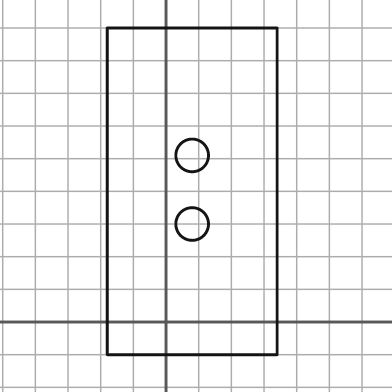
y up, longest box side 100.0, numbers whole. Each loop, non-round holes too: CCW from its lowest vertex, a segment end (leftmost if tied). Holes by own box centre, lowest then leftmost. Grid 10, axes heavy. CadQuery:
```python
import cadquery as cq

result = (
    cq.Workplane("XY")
    .moveTo(-18.0, -10.0)
    .lineTo(34.0, -10.0)
    .lineTo(34.0, 90.0)
    .lineTo(-18.0, 90.0)
    .close()
    .moveTo(8.0, 30.0)
    .circle(5.0)
    .moveTo(8.0, 51.0)
    .circle(5.0)
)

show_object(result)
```